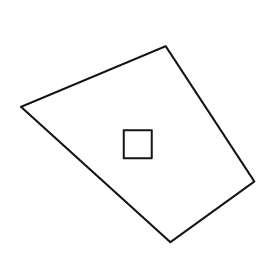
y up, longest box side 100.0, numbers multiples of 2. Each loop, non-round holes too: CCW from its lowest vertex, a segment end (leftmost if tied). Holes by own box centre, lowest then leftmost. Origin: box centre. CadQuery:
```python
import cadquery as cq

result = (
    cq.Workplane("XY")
    .moveTo(14.0, -42.0)
    .lineTo(50.0, -16.0)
    .lineTo(12.0, 42.0)
    .lineTo(-50.0, 16.0)
    .close()
    .moveTo(-6.0, -6.0)
    .lineTo(6.0, -6.0)
    .lineTo(6.0, 6.0)
    .lineTo(-6.0, 6.0)
    .close()
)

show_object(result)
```